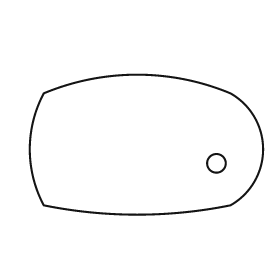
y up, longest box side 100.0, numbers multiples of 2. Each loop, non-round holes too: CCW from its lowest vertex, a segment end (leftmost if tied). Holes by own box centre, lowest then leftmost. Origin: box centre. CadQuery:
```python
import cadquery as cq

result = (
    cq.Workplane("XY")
    .moveTo(-44.0, -26.0)
    .threePointArc((-4.0, -30.0), (36.0, -26.0))
    .threePointArc((50.0, -2.0), (36.0, 22.0))
    .threePointArc((-4.0, 30.0), (-44.0, 22.0))
    .threePointArc((-50.0, -2.0), (-44.0, -26.0))
    .close()
    .moveTo(30.0, -8.0)
    .circle(4.0)
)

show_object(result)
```